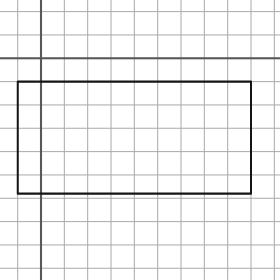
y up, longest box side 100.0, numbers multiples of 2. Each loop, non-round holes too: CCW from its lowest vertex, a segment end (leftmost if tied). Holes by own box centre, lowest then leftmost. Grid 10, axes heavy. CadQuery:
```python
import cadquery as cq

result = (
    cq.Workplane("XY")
    .moveTo(-10.0, -58.0)
    .lineTo(90.0, -58.0)
    .lineTo(90.0, -10.0)
    .lineTo(-10.0, -10.0)
    .close()
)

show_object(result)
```